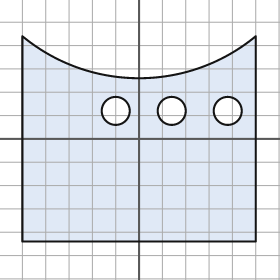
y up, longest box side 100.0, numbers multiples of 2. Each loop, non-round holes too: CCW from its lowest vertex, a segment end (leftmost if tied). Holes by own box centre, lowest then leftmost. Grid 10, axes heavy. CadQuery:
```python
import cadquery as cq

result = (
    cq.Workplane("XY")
    .moveTo(-50.0, -44.0)
    .lineTo(50.0, -44.0)
    .lineTo(50.0, 44.0)
    .threePointArc((0.0, 26.0), (-50.0, 44.0))
    .close()
    .moveTo(-10.0, 12.0)
    .circle(6.0)
    .moveTo(14.0, 12.0)
    .circle(6.0)
    .moveTo(38.0, 12.0)
    .circle(6.0)
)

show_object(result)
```